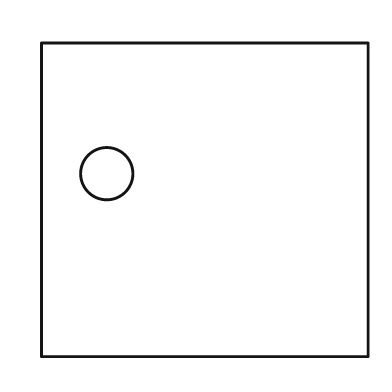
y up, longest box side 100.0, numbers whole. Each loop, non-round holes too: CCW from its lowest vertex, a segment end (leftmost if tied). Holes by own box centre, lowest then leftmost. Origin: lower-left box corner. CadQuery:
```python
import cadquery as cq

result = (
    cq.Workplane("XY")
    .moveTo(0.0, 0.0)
    .lineTo(100.0, 0.0)
    .lineTo(100.0, 96.0)
    .lineTo(0.0, 96.0)
    .close()
    .moveTo(20.0, 56.0)
    .circle(8.0)
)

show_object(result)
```